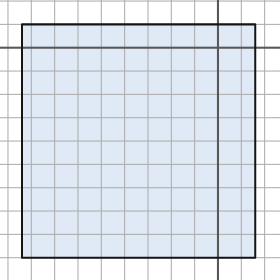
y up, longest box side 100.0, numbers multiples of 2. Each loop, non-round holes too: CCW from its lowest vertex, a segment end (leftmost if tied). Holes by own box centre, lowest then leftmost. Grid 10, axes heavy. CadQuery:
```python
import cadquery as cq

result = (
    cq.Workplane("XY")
    .moveTo(-84.0, -90.0)
    .lineTo(16.0, -90.0)
    .lineTo(16.0, 10.0)
    .lineTo(-84.0, 10.0)
    .close()
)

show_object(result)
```